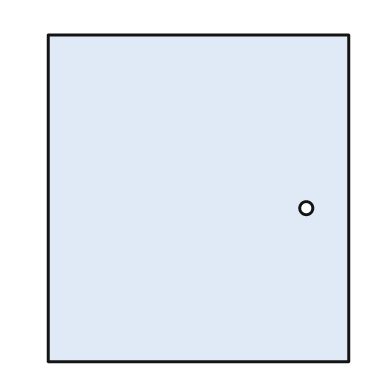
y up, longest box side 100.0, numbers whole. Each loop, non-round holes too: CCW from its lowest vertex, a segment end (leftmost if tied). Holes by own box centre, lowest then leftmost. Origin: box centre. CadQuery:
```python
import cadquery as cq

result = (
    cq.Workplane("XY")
    .moveTo(-46.0, -50.0)
    .lineTo(46.0, -50.0)
    .lineTo(46.0, 50.0)
    .lineTo(-46.0, 50.0)
    .close()
    .moveTo(33.0, -3.0)
    .circle(2.0)
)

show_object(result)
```